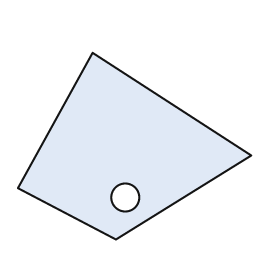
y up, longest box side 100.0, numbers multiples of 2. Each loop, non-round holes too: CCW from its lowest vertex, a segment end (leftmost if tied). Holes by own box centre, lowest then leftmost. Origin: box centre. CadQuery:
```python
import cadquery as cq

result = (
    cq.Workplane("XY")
    .moveTo(-8.0, -40.0)
    .lineTo(50.0, -4.0)
    .lineTo(-18.0, 40.0)
    .lineTo(-50.0, -18.0)
    .close()
    .moveTo(-4.0, -22.0)
    .circle(6.0)
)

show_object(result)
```